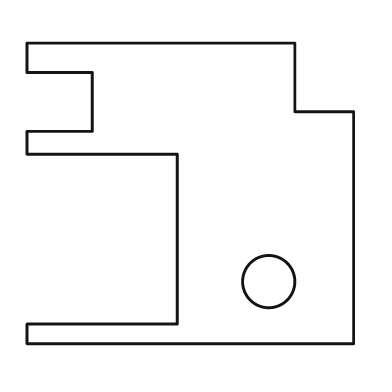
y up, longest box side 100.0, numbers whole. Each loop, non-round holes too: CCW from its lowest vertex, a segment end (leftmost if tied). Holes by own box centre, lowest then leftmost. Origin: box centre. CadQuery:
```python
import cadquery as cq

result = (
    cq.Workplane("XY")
    .moveTo(-50.0, -46.0)
    .lineTo(50.0, -46.0)
    .lineTo(50.0, 25.0)
    .lineTo(32.0, 25.0)
    .lineTo(32.0, 46.0)
    .lineTo(-50.0, 46.0)
    .lineTo(-50.0, 37.0)
    .lineTo(-30.0, 37.0)
    .lineTo(-30.0, 19.0)
    .lineTo(-50.0, 19.0)
    .lineTo(-50.0, 12.0)
    .lineTo(-4.0, 12.0)
    .lineTo(-4.0, -40.0)
    .lineTo(-50.0, -40.0)
    .close()
    .moveTo(24.0, -27.0)
    .circle(8.0)
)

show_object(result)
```